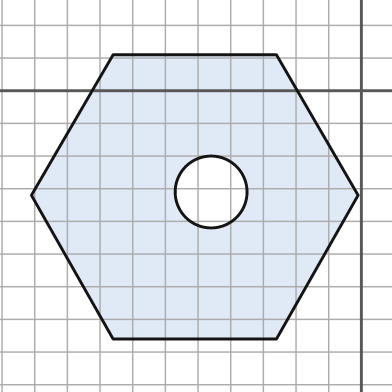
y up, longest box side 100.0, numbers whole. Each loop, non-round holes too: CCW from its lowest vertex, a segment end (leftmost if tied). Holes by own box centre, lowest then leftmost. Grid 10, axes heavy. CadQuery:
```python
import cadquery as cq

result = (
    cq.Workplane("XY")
    .moveTo(-76.0, -76.0)
    .lineTo(-26.0, -76.0)
    .lineTo(-1.0, -32.0)
    .lineTo(-26.0, 11.0)
    .lineTo(-76.0, 11.0)
    .lineTo(-101.0, -32.0)
    .close()
    .moveTo(-46.0, -31.0)
    .circle(11.0)
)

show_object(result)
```